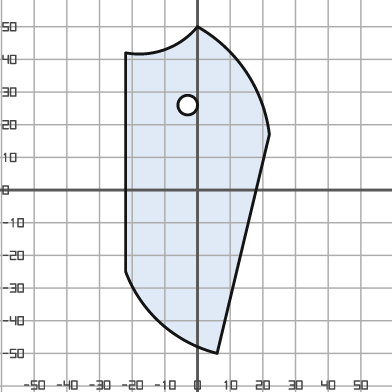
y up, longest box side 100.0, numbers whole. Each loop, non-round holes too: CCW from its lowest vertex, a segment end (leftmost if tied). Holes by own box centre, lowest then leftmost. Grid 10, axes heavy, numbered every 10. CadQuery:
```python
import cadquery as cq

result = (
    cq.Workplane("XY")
    .moveTo(6.0, -50.0)
    .lineTo(22.0, 17.0)
    .threePointArc((15.0, 36.0), (0.0, 50.0))
    .threePointArc((-10.0, 43.0), (-22.0, 42.0))
    .lineTo(-22.0, -25.0)
    .threePointArc((-11.0, -41.0), (6.0, -50.0))
    .close()
    .moveTo(-3.0, 26.0)
    .circle(3.0)
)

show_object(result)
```